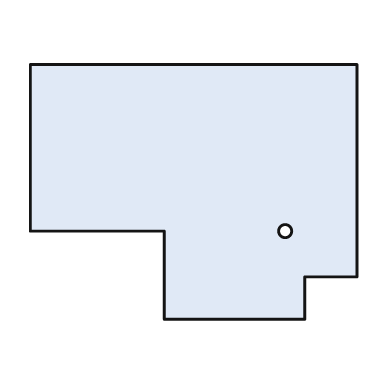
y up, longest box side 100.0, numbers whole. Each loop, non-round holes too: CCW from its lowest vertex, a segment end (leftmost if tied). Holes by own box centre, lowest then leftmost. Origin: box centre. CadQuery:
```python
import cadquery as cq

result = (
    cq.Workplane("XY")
    .moveTo(-9.0, -39.0)
    .lineTo(34.0, -39.0)
    .lineTo(34.0, -26.0)
    .lineTo(50.0, -26.0)
    .lineTo(50.0, 39.0)
    .lineTo(-50.0, 39.0)
    .lineTo(-50.0, -12.0)
    .lineTo(-9.0, -12.0)
    .close()
    .moveTo(28.0, -12.0)
    .circle(2.0)
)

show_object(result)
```